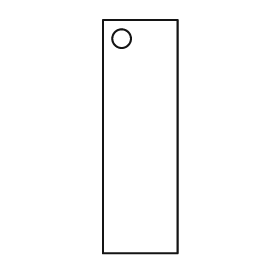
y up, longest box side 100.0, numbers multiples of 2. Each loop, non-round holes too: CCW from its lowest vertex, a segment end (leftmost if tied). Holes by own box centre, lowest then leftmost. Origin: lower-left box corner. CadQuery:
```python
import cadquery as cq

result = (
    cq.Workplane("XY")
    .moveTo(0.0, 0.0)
    .lineTo(32.0, 0.0)
    .lineTo(32.0, 100.0)
    .lineTo(0.0, 100.0)
    .close()
    .moveTo(8.0, 92.0)
    .circle(4.0)
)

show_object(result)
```